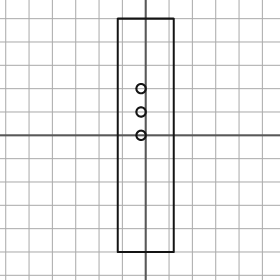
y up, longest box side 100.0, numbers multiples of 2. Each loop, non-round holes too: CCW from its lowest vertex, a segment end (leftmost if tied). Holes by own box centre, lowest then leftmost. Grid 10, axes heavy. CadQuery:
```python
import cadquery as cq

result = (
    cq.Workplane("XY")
    .moveTo(-12.0, -50.0)
    .lineTo(12.0, -50.0)
    .lineTo(12.0, 50.0)
    .lineTo(-12.0, 50.0)
    .close()
    .moveTo(-2.0, 0.0)
    .circle(2.0)
    .moveTo(-2.0, 10.0)
    .circle(2.0)
    .moveTo(-2.0, 20.0)
    .circle(2.0)
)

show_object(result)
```